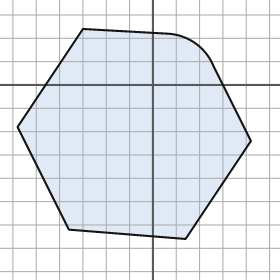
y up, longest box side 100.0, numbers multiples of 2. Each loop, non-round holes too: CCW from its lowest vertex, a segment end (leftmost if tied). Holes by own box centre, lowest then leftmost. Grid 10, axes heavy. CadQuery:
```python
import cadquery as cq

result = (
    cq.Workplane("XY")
    .moveTo(14.0, -66.0)
    .lineTo(42.0, -24.0)
    .lineTo(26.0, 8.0)
    .threePointArc((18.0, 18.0), (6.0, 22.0))
    .lineTo(-30.0, 24.0)
    .lineTo(-58.0, -18.0)
    .lineTo(-36.0, -62.0)
    .close()
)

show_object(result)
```